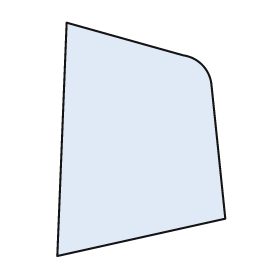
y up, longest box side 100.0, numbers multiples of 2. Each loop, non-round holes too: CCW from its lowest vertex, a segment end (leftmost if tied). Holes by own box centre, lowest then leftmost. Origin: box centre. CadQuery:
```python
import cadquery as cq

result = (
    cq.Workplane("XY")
    .moveTo(-36.0, -50.0)
    .lineTo(36.0, -34.0)
    .lineTo(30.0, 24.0)
    .threePointArc((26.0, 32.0), (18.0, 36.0))
    .lineTo(-32.0, 50.0)
    .close()
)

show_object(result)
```